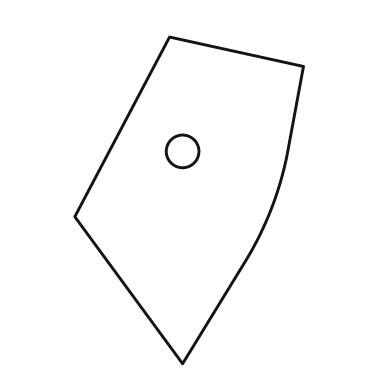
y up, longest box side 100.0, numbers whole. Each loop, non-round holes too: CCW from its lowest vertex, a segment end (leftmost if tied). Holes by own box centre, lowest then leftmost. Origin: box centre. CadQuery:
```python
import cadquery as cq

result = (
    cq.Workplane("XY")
    .moveTo(-2.0, -50.0)
    .lineTo(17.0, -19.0)
    .threePointArc((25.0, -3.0), (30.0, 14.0))
    .lineTo(35.0, 41.0)
    .lineTo(-6.0, 50.0)
    .lineTo(-35.0, -5.0)
    .close()
    .moveTo(-2.0, 15.0)
    .circle(5.0)
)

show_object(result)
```